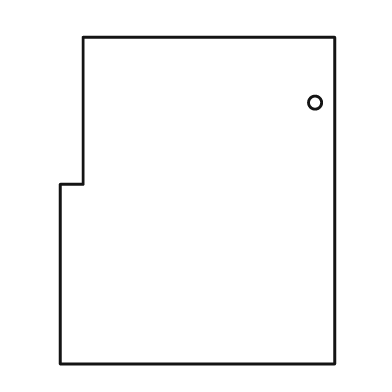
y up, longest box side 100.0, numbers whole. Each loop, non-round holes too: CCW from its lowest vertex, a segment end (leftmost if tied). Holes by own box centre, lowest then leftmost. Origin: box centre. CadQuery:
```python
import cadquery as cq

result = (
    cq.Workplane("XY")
    .moveTo(-42.0, -50.0)
    .lineTo(42.0, -50.0)
    .lineTo(42.0, 50.0)
    .lineTo(-35.0, 50.0)
    .lineTo(-35.0, 5.0)
    .lineTo(-42.0, 5.0)
    .close()
    .moveTo(36.0, 30.0)
    .circle(2.0)
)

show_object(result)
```